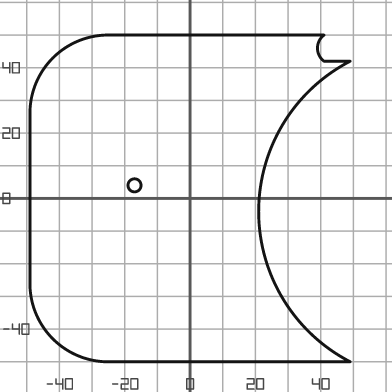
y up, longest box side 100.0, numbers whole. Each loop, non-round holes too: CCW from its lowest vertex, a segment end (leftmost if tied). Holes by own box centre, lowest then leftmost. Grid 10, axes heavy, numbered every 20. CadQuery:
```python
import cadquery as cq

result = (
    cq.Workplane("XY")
    .moveTo(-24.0, -50.0)
    .lineTo(49.0, -50.0)
    .threePointArc((21.0, -4.0), (49.0, 42.0))
    .lineTo(41.0, 42.0)
    .threePointArc((39.0, 46.0), (41.0, 50.0))
    .lineTo(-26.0, 50.0)
    .threePointArc((-42.0, 43.0), (-49.0, 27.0))
    .lineTo(-49.0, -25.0)
    .threePointArc((-42.0, -43.0), (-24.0, -50.0))
    .close()
    .moveTo(-17.0, 4.0)
    .circle(2.0)
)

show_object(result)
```